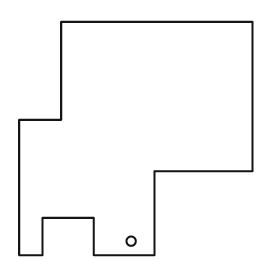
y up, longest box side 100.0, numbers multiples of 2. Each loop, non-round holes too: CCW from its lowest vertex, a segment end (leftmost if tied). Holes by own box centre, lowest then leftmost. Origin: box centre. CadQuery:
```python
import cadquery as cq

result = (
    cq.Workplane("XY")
    .moveTo(-50.0, -50.0)
    .lineTo(-40.0, -50.0)
    .lineTo(-40.0, -34.0)
    .lineTo(-18.0, -34.0)
    .lineTo(-18.0, -50.0)
    .lineTo(8.0, -50.0)
    .lineTo(8.0, -14.0)
    .lineTo(50.0, -14.0)
    .lineTo(50.0, 50.0)
    .lineTo(-32.0, 50.0)
    .lineTo(-32.0, 8.0)
    .lineTo(-50.0, 8.0)
    .close()
    .moveTo(-2.0, -44.0)
    .circle(2.0)
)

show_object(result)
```